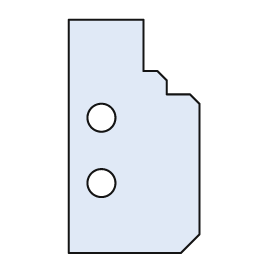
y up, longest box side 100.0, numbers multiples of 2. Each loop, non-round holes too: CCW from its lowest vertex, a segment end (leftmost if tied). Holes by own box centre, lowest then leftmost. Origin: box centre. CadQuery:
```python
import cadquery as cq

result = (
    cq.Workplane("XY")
    .moveTo(-28.0, -50.0)
    .lineTo(20.0, -50.0)
    .lineTo(28.0, -42.0)
    .lineTo(28.0, 14.0)
    .lineTo(24.0, 18.0)
    .lineTo(14.0, 18.0)
    .lineTo(14.0, 24.0)
    .lineTo(10.0, 28.0)
    .lineTo(4.0, 28.0)
    .lineTo(4.0, 50.0)
    .lineTo(-28.0, 50.0)
    .close()
    .moveTo(-14.0, -20.0)
    .circle(6.0)
    .moveTo(-14.0, 8.0)
    .circle(6.0)
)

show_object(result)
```